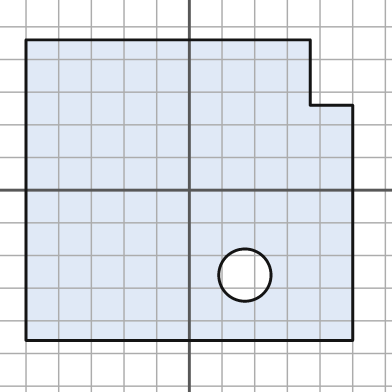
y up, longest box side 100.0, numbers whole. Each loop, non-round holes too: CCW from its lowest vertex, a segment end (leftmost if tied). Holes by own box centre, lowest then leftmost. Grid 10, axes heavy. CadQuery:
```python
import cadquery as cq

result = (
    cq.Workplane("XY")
    .moveTo(-50.0, -46.0)
    .lineTo(50.0, -46.0)
    .lineTo(50.0, 26.0)
    .lineTo(37.0, 26.0)
    .lineTo(37.0, 46.0)
    .lineTo(-50.0, 46.0)
    .close()
    .moveTo(17.0, -26.0)
    .circle(8.0)
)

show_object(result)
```